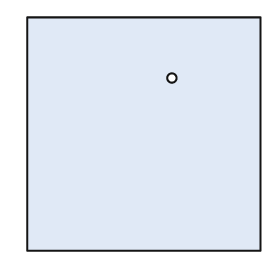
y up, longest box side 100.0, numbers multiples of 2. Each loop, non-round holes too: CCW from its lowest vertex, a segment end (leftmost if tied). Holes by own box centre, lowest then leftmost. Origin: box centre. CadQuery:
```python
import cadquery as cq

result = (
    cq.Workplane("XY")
    .moveTo(-50.0, -50.0)
    .lineTo(50.0, -50.0)
    .lineTo(50.0, 50.0)
    .lineTo(-50.0, 50.0)
    .close()
    .moveTo(12.0, 24.0)
    .circle(2.0)
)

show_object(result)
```